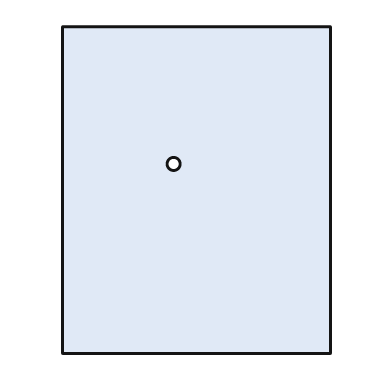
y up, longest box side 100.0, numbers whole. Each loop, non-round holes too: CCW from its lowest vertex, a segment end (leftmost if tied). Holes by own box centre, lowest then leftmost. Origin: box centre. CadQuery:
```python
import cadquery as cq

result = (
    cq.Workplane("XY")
    .moveTo(-41.0, -50.0)
    .lineTo(41.0, -50.0)
    .lineTo(41.0, 50.0)
    .lineTo(-41.0, 50.0)
    .close()
    .moveTo(-7.0, 8.0)
    .circle(2.0)
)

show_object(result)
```